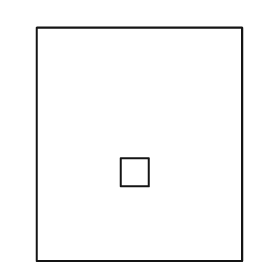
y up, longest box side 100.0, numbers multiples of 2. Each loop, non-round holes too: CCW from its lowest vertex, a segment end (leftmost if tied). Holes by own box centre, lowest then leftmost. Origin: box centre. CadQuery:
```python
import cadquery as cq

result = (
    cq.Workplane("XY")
    .moveTo(-44.0, -50.0)
    .lineTo(44.0, -50.0)
    .lineTo(44.0, 50.0)
    .lineTo(-44.0, 50.0)
    .close()
    .moveTo(-8.0, -18.0)
    .lineTo(4.0, -18.0)
    .lineTo(4.0, -6.0)
    .lineTo(-8.0, -6.0)
    .close()
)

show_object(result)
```